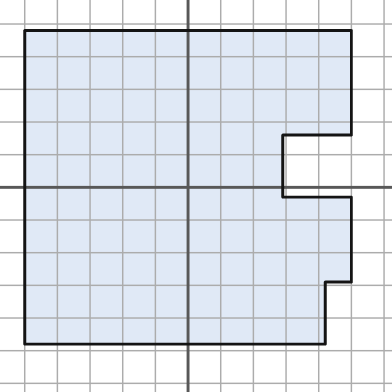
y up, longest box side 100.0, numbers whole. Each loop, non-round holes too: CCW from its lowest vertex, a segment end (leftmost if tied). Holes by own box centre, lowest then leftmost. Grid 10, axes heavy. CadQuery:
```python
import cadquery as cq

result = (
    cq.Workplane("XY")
    .moveTo(-50.0, -48.0)
    .lineTo(42.0, -48.0)
    .lineTo(42.0, -29.0)
    .lineTo(50.0, -29.0)
    .lineTo(50.0, -3.0)
    .lineTo(29.0, -3.0)
    .lineTo(29.0, 16.0)
    .lineTo(50.0, 16.0)
    .lineTo(50.0, 48.0)
    .lineTo(-50.0, 48.0)
    .close()
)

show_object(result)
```